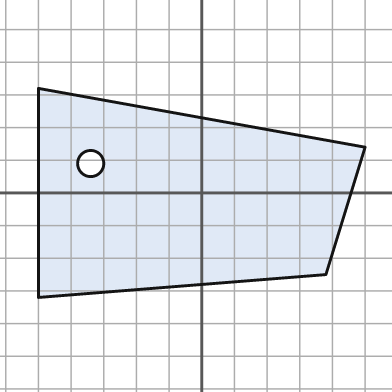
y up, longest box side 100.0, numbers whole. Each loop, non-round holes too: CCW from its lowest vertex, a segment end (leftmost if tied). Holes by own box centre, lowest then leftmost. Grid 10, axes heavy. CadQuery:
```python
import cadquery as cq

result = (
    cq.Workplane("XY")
    .moveTo(-50.0, -32.0)
    .lineTo(38.0, -25.0)
    .lineTo(50.0, 14.0)
    .lineTo(-50.0, 32.0)
    .close()
    .moveTo(-34.0, 9.0)
    .circle(4.0)
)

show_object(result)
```